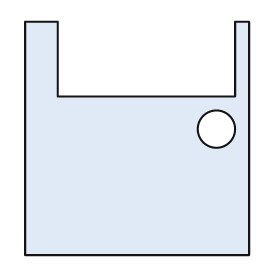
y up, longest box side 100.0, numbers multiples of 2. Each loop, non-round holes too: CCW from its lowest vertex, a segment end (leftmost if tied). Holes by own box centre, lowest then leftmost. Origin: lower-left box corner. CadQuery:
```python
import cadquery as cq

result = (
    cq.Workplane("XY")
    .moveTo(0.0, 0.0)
    .lineTo(96.0, 0.0)
    .lineTo(96.0, 100.0)
    .lineTo(90.0, 100.0)
    .lineTo(90.0, 68.0)
    .lineTo(14.0, 68.0)
    .lineTo(14.0, 100.0)
    .lineTo(0.0, 100.0)
    .close()
    .moveTo(82.0, 54.0)
    .circle(8.0)
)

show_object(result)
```